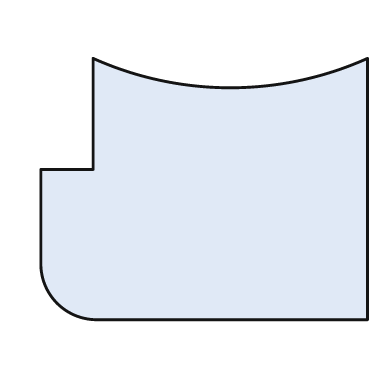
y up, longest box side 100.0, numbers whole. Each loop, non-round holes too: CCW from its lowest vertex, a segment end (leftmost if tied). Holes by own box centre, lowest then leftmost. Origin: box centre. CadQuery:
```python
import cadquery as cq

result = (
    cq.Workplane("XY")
    .moveTo(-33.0, -40.0)
    .lineTo(50.0, -40.0)
    .lineTo(50.0, 40.0)
    .threePointArc((8.0, 31.0), (-34.0, 40.0))
    .lineTo(-34.0, 6.0)
    .lineTo(-50.0, 6.0)
    .lineTo(-50.0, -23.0)
    .threePointArc((-45.0, -35.0), (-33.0, -40.0))
    .close()
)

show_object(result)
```